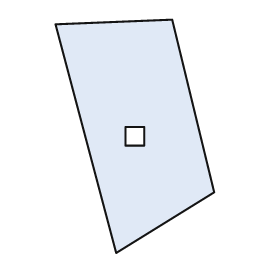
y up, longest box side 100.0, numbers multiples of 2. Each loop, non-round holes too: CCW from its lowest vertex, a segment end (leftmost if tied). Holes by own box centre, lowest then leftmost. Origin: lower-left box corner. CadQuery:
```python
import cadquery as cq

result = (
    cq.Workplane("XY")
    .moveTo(26.0, 0.0)
    .lineTo(68.0, 26.0)
    .lineTo(50.0, 100.0)
    .lineTo(0.0, 98.0)
    .close()
    .moveTo(30.0, 46.0)
    .lineTo(38.0, 46.0)
    .lineTo(38.0, 54.0)
    .lineTo(30.0, 54.0)
    .close()
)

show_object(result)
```